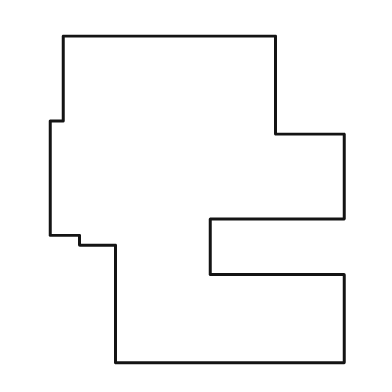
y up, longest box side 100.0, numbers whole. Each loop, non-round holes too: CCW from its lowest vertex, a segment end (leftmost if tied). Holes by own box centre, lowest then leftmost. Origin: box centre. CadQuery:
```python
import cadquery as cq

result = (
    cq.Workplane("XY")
    .moveTo(-25.0, -50.0)
    .lineTo(45.0, -50.0)
    .lineTo(45.0, -23.0)
    .lineTo(4.0, -23.0)
    .lineTo(4.0, -6.0)
    .lineTo(45.0, -6.0)
    .lineTo(45.0, 20.0)
    .lineTo(24.0, 20.0)
    .lineTo(24.0, 50.0)
    .lineTo(-41.0, 50.0)
    .lineTo(-41.0, 24.0)
    .lineTo(-45.0, 24.0)
    .lineTo(-45.0, -11.0)
    .lineTo(-36.0, -11.0)
    .lineTo(-36.0, -14.0)
    .lineTo(-25.0, -14.0)
    .close()
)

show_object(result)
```